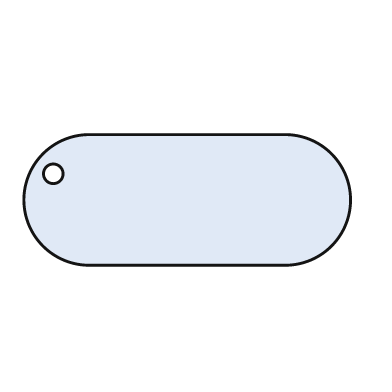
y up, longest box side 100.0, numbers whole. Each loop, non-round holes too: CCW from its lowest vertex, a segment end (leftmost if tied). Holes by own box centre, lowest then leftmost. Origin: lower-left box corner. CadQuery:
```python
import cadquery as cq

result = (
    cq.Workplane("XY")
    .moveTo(20.0, 0.0)
    .lineTo(80.0, 0.0)
    .threePointArc((100.0, 20.0), (80.0, 40.0))
    .lineTo(20.0, 40.0)
    .threePointArc((0.0, 20.0), (20.0, 0.0))
    .close()
    .moveTo(9.0, 28.0)
    .circle(3.0)
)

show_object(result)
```